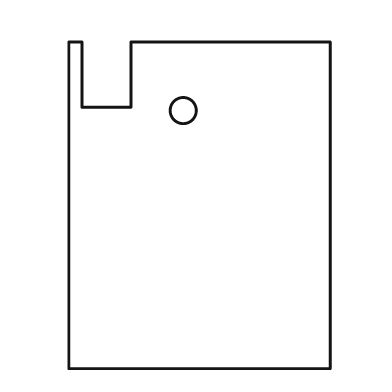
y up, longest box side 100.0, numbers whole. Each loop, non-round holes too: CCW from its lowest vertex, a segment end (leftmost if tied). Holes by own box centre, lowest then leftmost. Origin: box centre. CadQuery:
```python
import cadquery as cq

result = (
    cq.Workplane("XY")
    .moveTo(-40.0, -50.0)
    .lineTo(40.0, -50.0)
    .lineTo(40.0, 50.0)
    .lineTo(-21.0, 50.0)
    .lineTo(-21.0, 30.0)
    .lineTo(-36.0, 30.0)
    .lineTo(-36.0, 50.0)
    .lineTo(-40.0, 50.0)
    .close()
    .moveTo(-5.0, 29.0)
    .circle(4.0)
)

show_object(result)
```